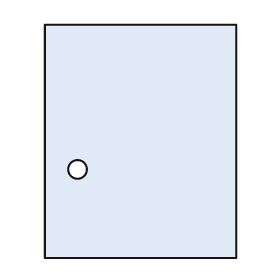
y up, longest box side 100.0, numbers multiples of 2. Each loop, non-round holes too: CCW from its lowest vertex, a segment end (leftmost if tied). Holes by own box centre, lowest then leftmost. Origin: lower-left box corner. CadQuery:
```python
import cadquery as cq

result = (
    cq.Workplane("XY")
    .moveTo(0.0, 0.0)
    .lineTo(82.0, 0.0)
    .lineTo(82.0, 100.0)
    .lineTo(0.0, 100.0)
    .close()
    .moveTo(14.0, 38.0)
    .circle(4.0)
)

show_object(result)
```